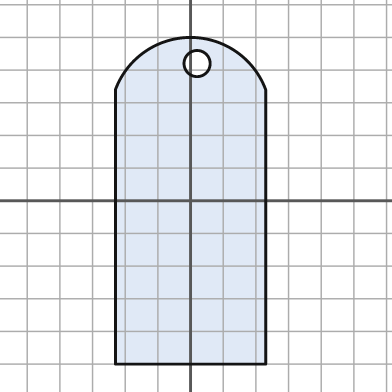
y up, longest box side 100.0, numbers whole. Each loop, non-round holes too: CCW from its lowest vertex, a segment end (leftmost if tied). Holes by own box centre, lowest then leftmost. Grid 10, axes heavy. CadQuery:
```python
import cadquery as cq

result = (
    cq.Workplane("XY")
    .moveTo(-23.0, -50.0)
    .lineTo(23.0, -50.0)
    .lineTo(23.0, 34.0)
    .threePointArc((0.0, 50.0), (-23.0, 34.0))
    .close()
    .moveTo(2.0, 42.0)
    .circle(4.0)
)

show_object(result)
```